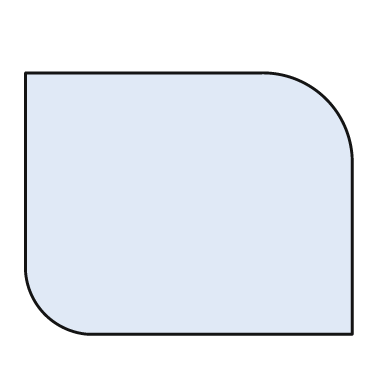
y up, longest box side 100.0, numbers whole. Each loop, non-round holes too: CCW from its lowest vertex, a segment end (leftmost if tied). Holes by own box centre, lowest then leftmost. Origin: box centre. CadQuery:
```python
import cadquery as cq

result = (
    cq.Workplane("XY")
    .moveTo(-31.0, -40.0)
    .lineTo(50.0, -40.0)
    .lineTo(50.0, 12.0)
    .threePointArc((42.0, 32.0), (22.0, 40.0))
    .lineTo(-50.0, 40.0)
    .lineTo(-50.0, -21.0)
    .threePointArc((-44.0, -34.0), (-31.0, -40.0))
    .close()
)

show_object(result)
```